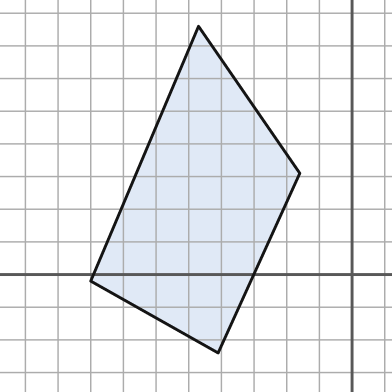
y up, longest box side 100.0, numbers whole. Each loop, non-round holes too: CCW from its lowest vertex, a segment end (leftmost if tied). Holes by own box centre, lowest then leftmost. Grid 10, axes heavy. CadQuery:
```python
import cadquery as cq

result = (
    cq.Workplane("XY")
    .moveTo(-41.0, -24.0)
    .lineTo(-16.0, 31.0)
    .lineTo(-47.0, 76.0)
    .lineTo(-80.0, -2.0)
    .close()
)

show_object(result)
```